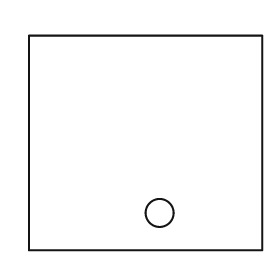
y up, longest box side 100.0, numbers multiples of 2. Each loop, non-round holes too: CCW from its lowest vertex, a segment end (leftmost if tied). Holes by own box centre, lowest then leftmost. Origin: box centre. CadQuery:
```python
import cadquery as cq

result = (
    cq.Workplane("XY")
    .moveTo(-50.0, -46.0)
    .lineTo(50.0, -46.0)
    .lineTo(50.0, 46.0)
    .lineTo(-50.0, 46.0)
    .close()
    .moveTo(6.0, -30.0)
    .circle(6.0)
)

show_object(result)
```